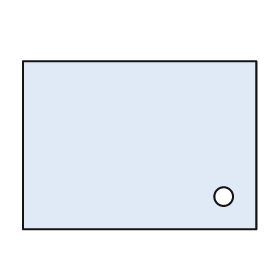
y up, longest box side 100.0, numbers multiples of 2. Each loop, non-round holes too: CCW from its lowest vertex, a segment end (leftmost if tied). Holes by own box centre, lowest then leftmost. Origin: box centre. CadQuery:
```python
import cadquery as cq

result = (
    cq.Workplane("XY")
    .moveTo(-50.0, -36.0)
    .lineTo(50.0, -36.0)
    .lineTo(50.0, 36.0)
    .lineTo(-50.0, 36.0)
    .close()
    .moveTo(36.0, -22.0)
    .circle(4.0)
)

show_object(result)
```